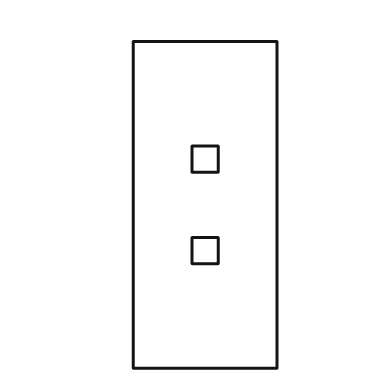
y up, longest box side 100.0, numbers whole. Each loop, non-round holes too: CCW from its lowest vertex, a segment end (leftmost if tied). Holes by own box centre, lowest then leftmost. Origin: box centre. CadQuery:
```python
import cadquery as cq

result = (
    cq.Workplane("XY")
    .moveTo(-22.0, -50.0)
    .lineTo(22.0, -50.0)
    .lineTo(22.0, 50.0)
    .lineTo(-22.0, 50.0)
    .close()
    .moveTo(-4.0, -18.0)
    .lineTo(4.0, -18.0)
    .lineTo(4.0, -10.0)
    .lineTo(-4.0, -10.0)
    .close()
    .moveTo(-4.0, 10.0)
    .lineTo(4.0, 10.0)
    .lineTo(4.0, 18.0)
    .lineTo(-4.0, 18.0)
    .close()
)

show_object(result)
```